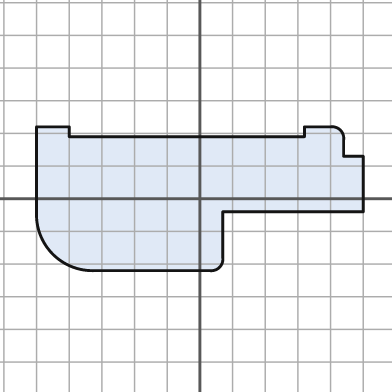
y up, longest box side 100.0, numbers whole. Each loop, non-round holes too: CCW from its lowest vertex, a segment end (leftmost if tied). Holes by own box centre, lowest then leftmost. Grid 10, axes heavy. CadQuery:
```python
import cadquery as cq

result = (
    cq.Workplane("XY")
    .moveTo(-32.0, -22.0)
    .lineTo(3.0, -22.0)
    .threePointArc((6.0, -21.0), (7.0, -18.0))
    .lineTo(7.0, -4.0)
    .lineTo(50.0, -4.0)
    .lineTo(50.0, 13.0)
    .lineTo(44.0, 13.0)
    .lineTo(44.0, 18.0)
    .threePointArc((43.0, 21.0), (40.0, 22.0))
    .lineTo(32.0, 22.0)
    .lineTo(32.0, 19.0)
    .lineTo(-40.0, 19.0)
    .lineTo(-40.0, 22.0)
    .lineTo(-50.0, 22.0)
    .lineTo(-50.0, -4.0)
    .threePointArc((-45.0, -17.0), (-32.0, -22.0))
    .close()
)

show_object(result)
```